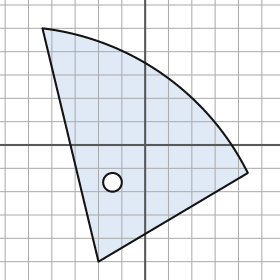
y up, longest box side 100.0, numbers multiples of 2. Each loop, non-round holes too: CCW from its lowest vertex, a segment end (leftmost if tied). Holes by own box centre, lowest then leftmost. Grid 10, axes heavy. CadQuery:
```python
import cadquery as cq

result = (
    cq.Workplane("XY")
    .moveTo(-20.0, -50.0)
    .lineTo(44.0, -12.0)
    .threePointArc((8.0, 30.0), (-44.0, 50.0))
    .close()
    .moveTo(-14.0, -16.0)
    .circle(4.0)
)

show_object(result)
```